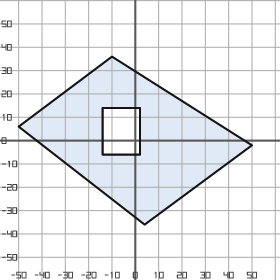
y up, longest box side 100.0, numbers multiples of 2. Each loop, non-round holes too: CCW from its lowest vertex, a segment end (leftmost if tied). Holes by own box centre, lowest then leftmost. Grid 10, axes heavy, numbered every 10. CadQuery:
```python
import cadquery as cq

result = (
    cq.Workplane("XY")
    .moveTo(4.0, -36.0)
    .lineTo(50.0, -2.0)
    .lineTo(-10.0, 36.0)
    .lineTo(-50.0, 6.0)
    .close()
    .moveTo(-14.0, -6.0)
    .lineTo(2.0, -6.0)
    .lineTo(2.0, 14.0)
    .lineTo(-14.0, 14.0)
    .close()
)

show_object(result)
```